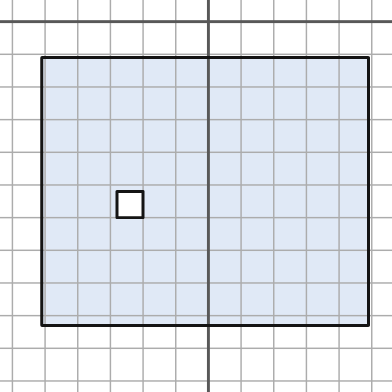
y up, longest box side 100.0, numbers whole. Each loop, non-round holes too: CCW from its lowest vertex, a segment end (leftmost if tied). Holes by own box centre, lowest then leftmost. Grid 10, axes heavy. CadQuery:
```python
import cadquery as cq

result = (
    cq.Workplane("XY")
    .moveTo(-51.0, -93.0)
    .lineTo(49.0, -93.0)
    .lineTo(49.0, -11.0)
    .lineTo(-51.0, -11.0)
    .close()
    .moveTo(-28.0, -60.0)
    .lineTo(-20.0, -60.0)
    .lineTo(-20.0, -52.0)
    .lineTo(-28.0, -52.0)
    .close()
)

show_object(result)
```